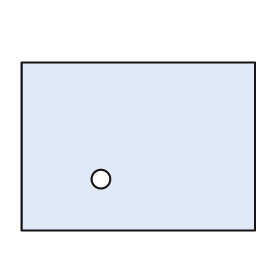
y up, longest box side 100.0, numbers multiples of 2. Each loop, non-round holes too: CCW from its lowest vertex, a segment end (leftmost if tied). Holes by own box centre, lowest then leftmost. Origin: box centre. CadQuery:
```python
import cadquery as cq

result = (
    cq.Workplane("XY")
    .moveTo(-50.0, -36.0)
    .lineTo(50.0, -36.0)
    .lineTo(50.0, 36.0)
    .lineTo(-50.0, 36.0)
    .close()
    .moveTo(-16.0, -14.0)
    .circle(4.0)
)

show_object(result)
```